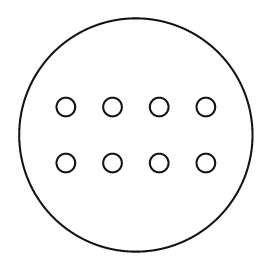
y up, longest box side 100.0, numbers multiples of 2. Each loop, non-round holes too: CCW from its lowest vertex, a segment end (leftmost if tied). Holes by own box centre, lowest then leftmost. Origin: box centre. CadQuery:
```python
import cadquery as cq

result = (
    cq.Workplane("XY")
    .moveTo(0.0, 0.0)
    .circle(50.0)
    .moveTo(-30.0, -12.0)
    .circle(4.0)
    .moveTo(-10.0, -12.0)
    .circle(4.0)
    .moveTo(10.0, -12.0)
    .circle(4.0)
    .moveTo(30.0, -12.0)
    .circle(4.0)
    .moveTo(-30.0, 12.0)
    .circle(4.0)
    .moveTo(-10.0, 12.0)
    .circle(4.0)
    .moveTo(10.0, 12.0)
    .circle(4.0)
    .moveTo(30.0, 12.0)
    .circle(4.0)
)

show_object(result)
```